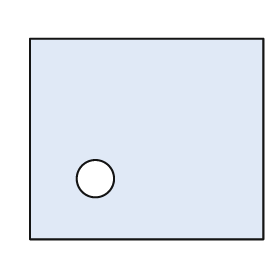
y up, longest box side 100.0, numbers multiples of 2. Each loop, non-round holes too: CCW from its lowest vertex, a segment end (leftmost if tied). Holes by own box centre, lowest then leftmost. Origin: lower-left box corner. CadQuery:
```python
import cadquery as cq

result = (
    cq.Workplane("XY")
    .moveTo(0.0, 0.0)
    .lineTo(100.0, 0.0)
    .lineTo(100.0, 86.0)
    .lineTo(0.0, 86.0)
    .close()
    .moveTo(28.0, 26.0)
    .circle(8.0)
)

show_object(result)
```